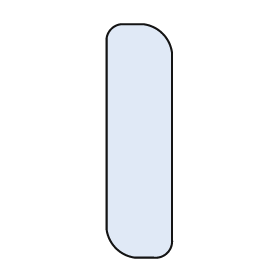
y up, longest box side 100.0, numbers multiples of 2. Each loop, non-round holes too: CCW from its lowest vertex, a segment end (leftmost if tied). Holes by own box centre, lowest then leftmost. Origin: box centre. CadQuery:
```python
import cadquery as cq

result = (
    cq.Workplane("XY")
    .moveTo(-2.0, -50.0)
    .lineTo(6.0, -50.0)
    .threePointArc((12.0, -48.0), (14.0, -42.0))
    .lineTo(14.0, 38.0)
    .threePointArc((10.0, 46.0), (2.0, 50.0))
    .lineTo(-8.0, 50.0)
    .threePointArc((-12.0, 48.0), (-14.0, 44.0))
    .lineTo(-14.0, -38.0)
    .threePointArc((-10.0, -46.0), (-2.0, -50.0))
    .close()
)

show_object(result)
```